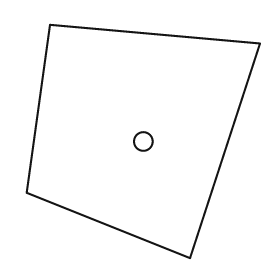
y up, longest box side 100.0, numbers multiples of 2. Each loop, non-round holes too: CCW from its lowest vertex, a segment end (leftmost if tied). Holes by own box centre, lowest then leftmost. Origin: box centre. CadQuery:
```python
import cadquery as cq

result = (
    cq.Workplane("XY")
    .moveTo(20.0, -50.0)
    .lineTo(50.0, 42.0)
    .lineTo(-40.0, 50.0)
    .lineTo(-50.0, -22.0)
    .close()
    .moveTo(0.0, 0.0)
    .circle(4.0)
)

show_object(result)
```